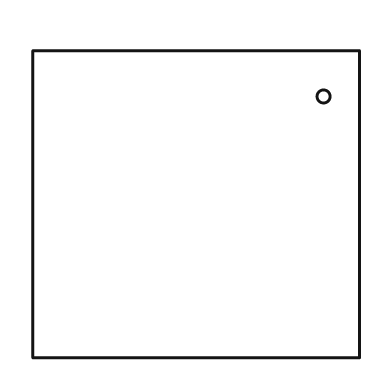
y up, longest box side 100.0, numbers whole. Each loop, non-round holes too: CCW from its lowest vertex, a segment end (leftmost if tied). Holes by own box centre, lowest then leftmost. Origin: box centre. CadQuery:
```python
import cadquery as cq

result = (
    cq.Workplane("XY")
    .moveTo(-50.0, -47.0)
    .lineTo(50.0, -47.0)
    .lineTo(50.0, 47.0)
    .lineTo(-50.0, 47.0)
    .close()
    .moveTo(39.0, 33.0)
    .circle(2.0)
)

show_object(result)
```